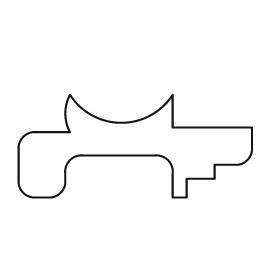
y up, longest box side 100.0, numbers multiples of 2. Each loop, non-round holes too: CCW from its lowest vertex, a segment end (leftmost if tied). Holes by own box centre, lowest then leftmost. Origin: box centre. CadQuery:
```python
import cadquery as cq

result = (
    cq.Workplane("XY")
    .moveTo(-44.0, -22.0)
    .lineTo(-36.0, -22.0)
    .threePointArc((-32.0, -20.0), (-30.0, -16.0))
    .lineTo(-30.0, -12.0)
    .threePointArc((-28.0, -6.0), (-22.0, -4.0))
    .lineTo(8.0, -4.0)
    .threePointArc((14.0, -6.0), (16.0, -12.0))
    .lineTo(16.0, -22.0)
    .lineTo(22.0, -22.0)
    .lineTo(22.0, -14.0)
    .lineTo(34.0, -14.0)
    .lineTo(34.0, -8.0)
    .lineTo(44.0, -8.0)
    .threePointArc((48.0, -6.0), (50.0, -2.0))
    .lineTo(50.0, 8.0)
    .lineTo(16.0, 8.0)
    .lineTo(16.0, 22.0)
    .threePointArc((-6.0, 10.0), (-28.0, 22.0))
    .threePointArc((-30.0, 14.0), (-28.0, 6.0))
    .lineTo(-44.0, 6.0)
    .threePointArc((-48.0, 4.0), (-50.0, 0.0))
    .lineTo(-50.0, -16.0)
    .threePointArc((-48.0, -20.0), (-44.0, -22.0))
    .close()
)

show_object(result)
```